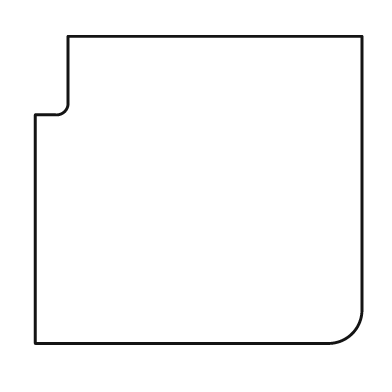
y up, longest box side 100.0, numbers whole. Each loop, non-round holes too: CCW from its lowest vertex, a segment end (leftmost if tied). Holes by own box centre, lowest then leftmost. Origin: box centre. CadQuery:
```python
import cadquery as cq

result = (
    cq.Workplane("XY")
    .moveTo(-50.0, -47.0)
    .lineTo(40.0, -47.0)
    .threePointArc((47.0, -44.0), (50.0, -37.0))
    .lineTo(50.0, 47.0)
    .lineTo(-40.0, 47.0)
    .lineTo(-40.0, 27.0)
    .threePointArc((-41.0, 24.0), (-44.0, 23.0))
    .lineTo(-50.0, 23.0)
    .close()
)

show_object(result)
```